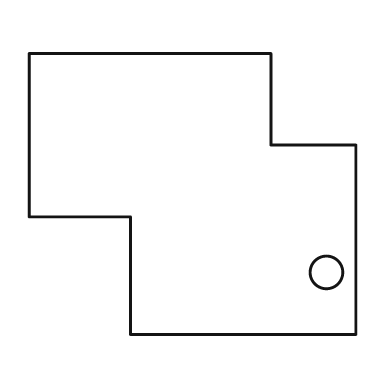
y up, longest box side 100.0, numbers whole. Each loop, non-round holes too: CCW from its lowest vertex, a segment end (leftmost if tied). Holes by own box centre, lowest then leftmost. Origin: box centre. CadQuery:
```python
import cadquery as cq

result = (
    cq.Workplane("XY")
    .moveTo(-19.0, -43.0)
    .lineTo(50.0, -43.0)
    .lineTo(50.0, 15.0)
    .lineTo(24.0, 15.0)
    .lineTo(24.0, 43.0)
    .lineTo(-50.0, 43.0)
    .lineTo(-50.0, -7.0)
    .lineTo(-19.0, -7.0)
    .close()
    .moveTo(41.0, -24.0)
    .circle(5.0)
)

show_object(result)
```